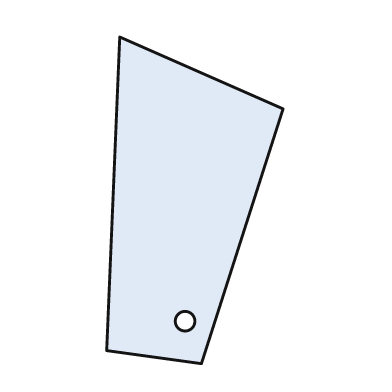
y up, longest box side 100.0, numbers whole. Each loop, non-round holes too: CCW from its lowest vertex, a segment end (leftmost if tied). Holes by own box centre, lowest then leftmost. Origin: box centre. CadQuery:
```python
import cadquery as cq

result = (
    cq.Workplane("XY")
    .moveTo(2.0, -50.0)
    .lineTo(27.0, 28.0)
    .lineTo(-23.0, 50.0)
    .lineTo(-27.0, -46.0)
    .close()
    .moveTo(-3.0, -37.0)
    .circle(3.0)
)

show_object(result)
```